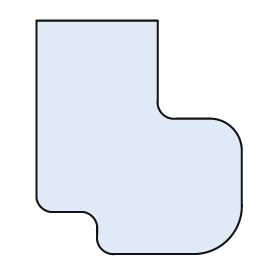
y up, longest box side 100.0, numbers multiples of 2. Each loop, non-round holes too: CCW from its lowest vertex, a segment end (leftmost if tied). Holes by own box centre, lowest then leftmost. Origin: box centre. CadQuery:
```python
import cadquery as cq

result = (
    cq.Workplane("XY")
    .moveTo(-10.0, -50.0)
    .lineTo(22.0, -50.0)
    .threePointArc((38.0, -44.0), (44.0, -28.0))
    .lineTo(44.0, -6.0)
    .threePointArc((40.0, 4.0), (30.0, 8.0))
    .lineTo(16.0, 8.0)
    .threePointArc((10.0, 10.0), (8.0, 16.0))
    .lineTo(8.0, 50.0)
    .lineTo(-44.0, 50.0)
    .lineTo(-44.0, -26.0)
    .threePointArc((-42.0, -30.0), (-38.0, -32.0))
    .lineTo(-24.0, -32.0)
    .threePointArc((-20.0, -34.0), (-18.0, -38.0))
    .lineTo(-18.0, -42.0)
    .threePointArc((-16.0, -48.0), (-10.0, -50.0))
    .close()
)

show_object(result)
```